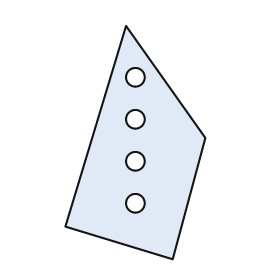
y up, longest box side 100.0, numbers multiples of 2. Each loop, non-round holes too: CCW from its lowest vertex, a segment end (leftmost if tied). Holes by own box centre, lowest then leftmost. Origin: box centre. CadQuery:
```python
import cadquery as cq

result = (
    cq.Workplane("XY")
    .moveTo(16.0, -50.0)
    .lineTo(30.0, 2.0)
    .lineTo(-4.0, 50.0)
    .lineTo(-30.0, -36.0)
    .close()
    .moveTo(0.0, -26.0)
    .circle(4.0)
    .moveTo(0.0, -8.0)
    .circle(4.0)
    .moveTo(0.0, 10.0)
    .circle(4.0)
    .moveTo(0.0, 28.0)
    .circle(4.0)
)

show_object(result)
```